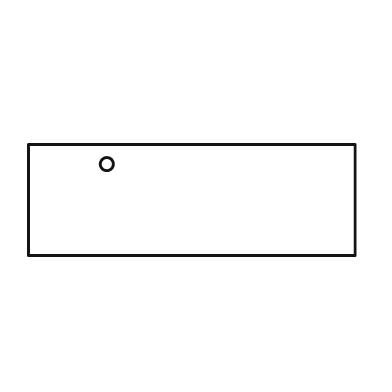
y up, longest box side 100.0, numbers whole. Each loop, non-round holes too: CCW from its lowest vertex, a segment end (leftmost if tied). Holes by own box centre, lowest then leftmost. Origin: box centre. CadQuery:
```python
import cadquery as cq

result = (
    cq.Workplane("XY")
    .moveTo(-50.0, -17.0)
    .lineTo(50.0, -17.0)
    .lineTo(50.0, 17.0)
    .lineTo(-50.0, 17.0)
    .close()
    .moveTo(-26.0, 11.0)
    .circle(2.0)
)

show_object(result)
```